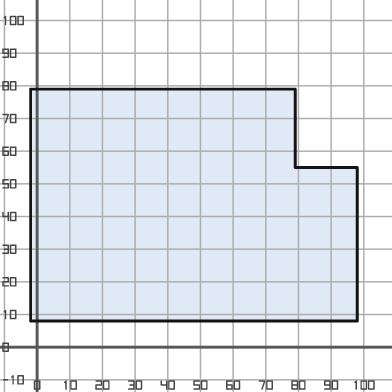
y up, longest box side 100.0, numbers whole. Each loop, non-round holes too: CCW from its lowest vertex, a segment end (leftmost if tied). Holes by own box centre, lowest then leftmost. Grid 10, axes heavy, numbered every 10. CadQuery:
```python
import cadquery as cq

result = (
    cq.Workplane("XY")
    .moveTo(-2.0, 8.0)
    .lineTo(98.0, 8.0)
    .lineTo(98.0, 55.0)
    .lineTo(79.0, 55.0)
    .lineTo(79.0, 79.0)
    .lineTo(-2.0, 79.0)
    .close()
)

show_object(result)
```